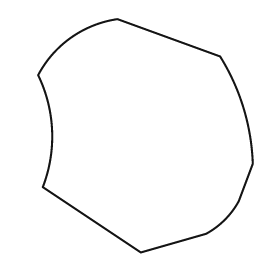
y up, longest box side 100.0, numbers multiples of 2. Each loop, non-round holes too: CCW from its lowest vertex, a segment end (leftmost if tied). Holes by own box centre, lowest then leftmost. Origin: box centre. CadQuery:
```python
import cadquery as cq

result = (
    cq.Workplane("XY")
    .moveTo(-2.0, -50.0)
    .lineTo(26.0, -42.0)
    .threePointArc((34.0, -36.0), (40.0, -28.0))
    .lineTo(46.0, -12.0)
    .threePointArc((42.0, 12.0), (32.0, 34.0))
    .lineTo(-12.0, 50.0)
    .threePointArc((-32.0, 42.0), (-46.0, 26.0))
    .threePointArc((-40.0, 2.0), (-44.0, -22.0))
    .close()
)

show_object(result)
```